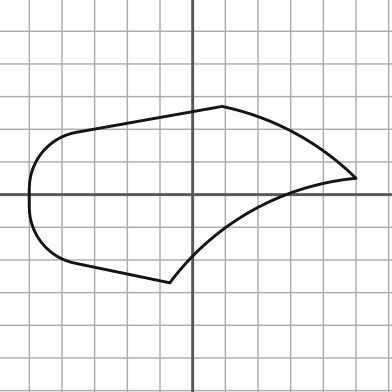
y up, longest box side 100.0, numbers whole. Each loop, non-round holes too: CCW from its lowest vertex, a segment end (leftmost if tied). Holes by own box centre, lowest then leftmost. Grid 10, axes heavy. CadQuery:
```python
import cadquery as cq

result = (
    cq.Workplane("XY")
    .moveTo(-7.0, -27.0)
    .threePointArc((18.0, -5.0), (50.0, 5.0))
    .threePointArc((31.0, 19.0), (9.0, 27.0))
    .lineTo(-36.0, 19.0)
    .threePointArc((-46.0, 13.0), (-50.0, 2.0))
    .lineTo(-50.0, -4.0)
    .threePointArc((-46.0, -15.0), (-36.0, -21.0))
    .close()
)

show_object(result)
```